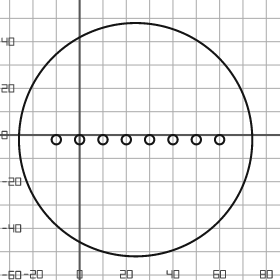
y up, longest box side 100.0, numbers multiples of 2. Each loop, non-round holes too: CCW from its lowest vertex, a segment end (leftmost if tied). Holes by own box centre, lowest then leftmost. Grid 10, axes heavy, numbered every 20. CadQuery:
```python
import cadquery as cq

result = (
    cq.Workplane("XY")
    .moveTo(24.0, -2.0)
    .circle(50.0)
    .moveTo(-10.0, -2.0)
    .circle(2.0)
    .moveTo(0.0, -2.0)
    .circle(2.0)
    .moveTo(10.0, -2.0)
    .circle(2.0)
    .moveTo(20.0, -2.0)
    .circle(2.0)
    .moveTo(30.0, -2.0)
    .circle(2.0)
    .moveTo(40.0, -2.0)
    .circle(2.0)
    .moveTo(50.0, -2.0)
    .circle(2.0)
    .moveTo(60.0, -2.0)
    .circle(2.0)
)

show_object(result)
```